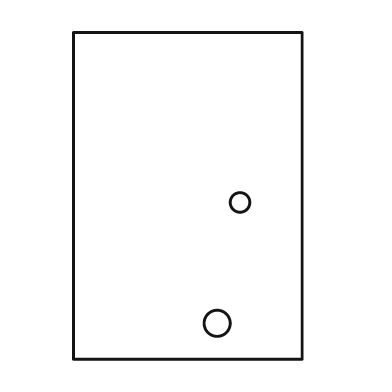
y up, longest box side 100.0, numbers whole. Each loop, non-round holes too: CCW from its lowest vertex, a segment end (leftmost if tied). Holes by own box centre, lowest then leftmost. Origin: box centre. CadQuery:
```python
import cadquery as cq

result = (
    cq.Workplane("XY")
    .moveTo(-35.0, -50.0)
    .lineTo(35.0, -50.0)
    .lineTo(35.0, 50.0)
    .lineTo(-35.0, 50.0)
    .close()
    .moveTo(9.0, -39.0)
    .circle(4.0)
    .moveTo(16.0, -2.0)
    .circle(3.0)
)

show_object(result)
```